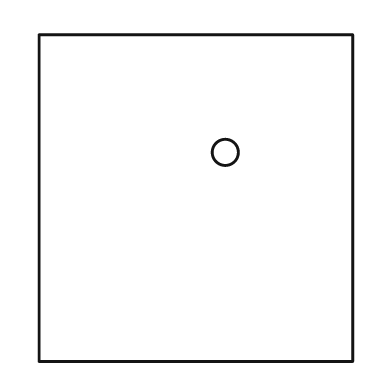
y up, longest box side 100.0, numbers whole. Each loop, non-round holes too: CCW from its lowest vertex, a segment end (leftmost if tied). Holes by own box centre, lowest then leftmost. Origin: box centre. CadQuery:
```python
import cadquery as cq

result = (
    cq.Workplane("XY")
    .moveTo(-48.0, -50.0)
    .lineTo(48.0, -50.0)
    .lineTo(48.0, 50.0)
    .lineTo(-48.0, 50.0)
    .close()
    .moveTo(9.0, 14.0)
    .circle(4.0)
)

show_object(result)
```